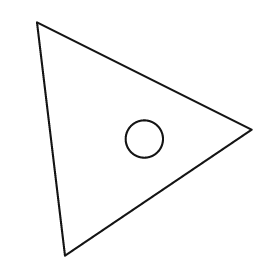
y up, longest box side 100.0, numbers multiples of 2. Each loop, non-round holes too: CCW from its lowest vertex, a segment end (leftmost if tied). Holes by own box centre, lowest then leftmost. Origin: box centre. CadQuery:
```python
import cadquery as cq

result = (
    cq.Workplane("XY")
    .moveTo(-34.0, -50.0)
    .lineTo(46.0, 4.0)
    .lineTo(-46.0, 50.0)
    .close()
    .moveTo(0.0, 0.0)
    .circle(8.0)
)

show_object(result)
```